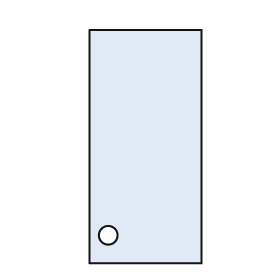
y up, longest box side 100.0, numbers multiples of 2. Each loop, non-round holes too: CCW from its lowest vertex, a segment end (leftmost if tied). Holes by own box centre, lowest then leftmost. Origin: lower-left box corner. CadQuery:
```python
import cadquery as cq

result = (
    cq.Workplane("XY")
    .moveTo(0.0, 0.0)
    .lineTo(48.0, 0.0)
    .lineTo(48.0, 100.0)
    .lineTo(0.0, 100.0)
    .close()
    .moveTo(8.0, 12.0)
    .circle(4.0)
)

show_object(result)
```